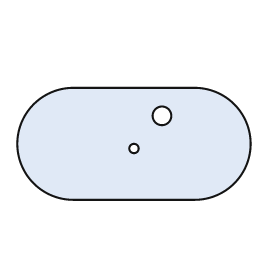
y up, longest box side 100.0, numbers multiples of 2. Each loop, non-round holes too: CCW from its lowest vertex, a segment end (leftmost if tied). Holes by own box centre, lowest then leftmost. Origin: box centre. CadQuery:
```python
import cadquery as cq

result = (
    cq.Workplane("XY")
    .moveTo(-26.0, -24.0)
    .lineTo(26.0, -24.0)
    .threePointArc((50.0, 0.0), (26.0, 24.0))
    .lineTo(-26.0, 24.0)
    .threePointArc((-50.0, 0.0), (-26.0, -24.0))
    .close()
    .moveTo(0.0, -2.0)
    .circle(2.0)
    .moveTo(12.0, 12.0)
    .circle(4.0)
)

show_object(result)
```